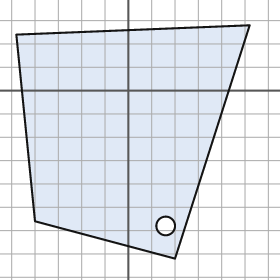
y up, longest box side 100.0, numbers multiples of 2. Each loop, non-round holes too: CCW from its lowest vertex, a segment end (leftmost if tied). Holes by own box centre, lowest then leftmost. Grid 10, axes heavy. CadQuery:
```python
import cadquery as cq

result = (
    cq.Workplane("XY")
    .moveTo(20.0, -72.0)
    .lineTo(52.0, 28.0)
    .lineTo(-48.0, 24.0)
    .lineTo(-40.0, -56.0)
    .close()
    .moveTo(16.0, -58.0)
    .circle(4.0)
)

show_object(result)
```